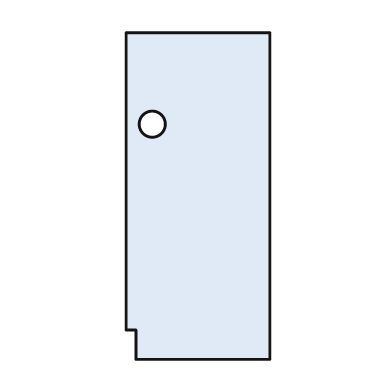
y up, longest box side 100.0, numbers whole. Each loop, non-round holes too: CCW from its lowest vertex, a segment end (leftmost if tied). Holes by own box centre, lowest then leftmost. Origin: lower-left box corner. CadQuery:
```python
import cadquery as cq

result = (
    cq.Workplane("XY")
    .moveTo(3.0, 0.0)
    .lineTo(44.0, 0.0)
    .lineTo(44.0, 100.0)
    .lineTo(0.0, 100.0)
    .lineTo(0.0, 9.0)
    .lineTo(3.0, 9.0)
    .close()
    .moveTo(8.0, 72.0)
    .circle(4.0)
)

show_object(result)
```